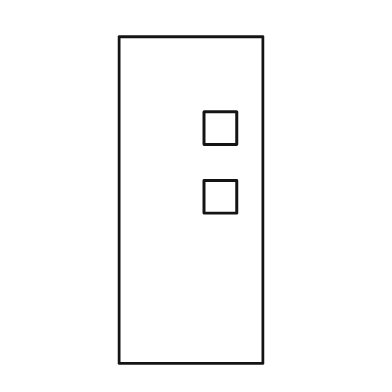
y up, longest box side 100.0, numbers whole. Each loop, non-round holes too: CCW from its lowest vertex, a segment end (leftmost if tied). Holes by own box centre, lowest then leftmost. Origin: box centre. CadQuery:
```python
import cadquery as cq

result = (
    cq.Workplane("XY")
    .moveTo(-22.0, -50.0)
    .lineTo(22.0, -50.0)
    .lineTo(22.0, 50.0)
    .lineTo(-22.0, 50.0)
    .close()
    .moveTo(4.0, -4.0)
    .lineTo(14.0, -4.0)
    .lineTo(14.0, 6.0)
    .lineTo(4.0, 6.0)
    .close()
    .moveTo(4.0, 17.0)
    .lineTo(14.0, 17.0)
    .lineTo(14.0, 27.0)
    .lineTo(4.0, 27.0)
    .close()
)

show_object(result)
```